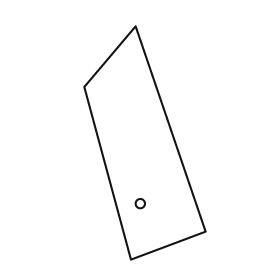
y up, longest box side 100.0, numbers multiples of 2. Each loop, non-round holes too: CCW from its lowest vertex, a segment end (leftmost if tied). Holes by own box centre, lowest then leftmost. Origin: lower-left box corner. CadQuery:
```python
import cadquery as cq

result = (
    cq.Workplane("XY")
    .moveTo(20.0, 0.0)
    .lineTo(52.0, 12.0)
    .lineTo(22.0, 100.0)
    .lineTo(0.0, 74.0)
    .close()
    .moveTo(24.0, 24.0)
    .circle(2.0)
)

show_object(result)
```